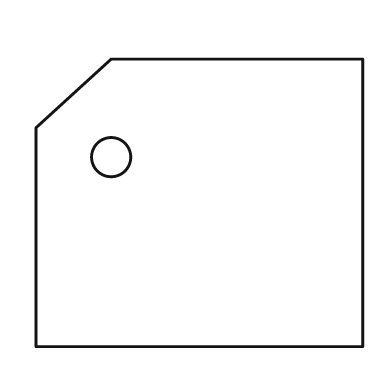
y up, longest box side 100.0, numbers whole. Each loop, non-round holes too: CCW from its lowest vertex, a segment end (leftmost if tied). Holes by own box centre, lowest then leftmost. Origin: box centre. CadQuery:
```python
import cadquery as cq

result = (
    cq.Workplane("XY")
    .moveTo(-50.0, -44.0)
    .lineTo(50.0, -44.0)
    .lineTo(50.0, 44.0)
    .lineTo(-27.0, 44.0)
    .lineTo(-50.0, 23.0)
    .close()
    .moveTo(-27.0, 14.0)
    .circle(6.0)
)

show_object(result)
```